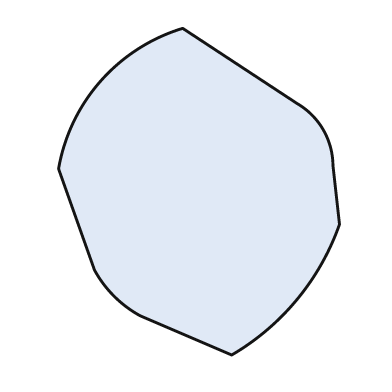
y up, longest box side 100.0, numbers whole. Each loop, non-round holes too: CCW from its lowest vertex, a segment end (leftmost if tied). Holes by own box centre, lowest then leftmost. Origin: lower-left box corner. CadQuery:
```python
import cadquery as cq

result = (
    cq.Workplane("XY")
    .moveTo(53.0, 0.0)
    .threePointArc((73.0, 17.0), (86.0, 40.0))
    .lineTo(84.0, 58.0)
    .threePointArc((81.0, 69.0), (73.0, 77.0))
    .lineTo(38.0, 100.0)
    .threePointArc((13.0, 84.0), (0.0, 57.0))
    .lineTo(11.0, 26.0)
    .threePointArc((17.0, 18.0), (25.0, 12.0))
    .close()
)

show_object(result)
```